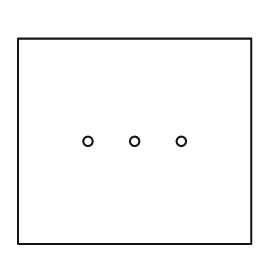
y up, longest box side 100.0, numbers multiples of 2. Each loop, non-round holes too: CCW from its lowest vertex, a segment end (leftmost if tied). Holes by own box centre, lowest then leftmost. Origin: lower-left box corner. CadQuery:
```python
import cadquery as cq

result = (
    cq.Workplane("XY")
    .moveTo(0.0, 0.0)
    .lineTo(100.0, 0.0)
    .lineTo(100.0, 88.0)
    .lineTo(0.0, 88.0)
    .close()
    .moveTo(30.0, 44.0)
    .circle(2.0)
    .moveTo(50.0, 44.0)
    .circle(2.0)
    .moveTo(70.0, 44.0)
    .circle(2.0)
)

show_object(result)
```